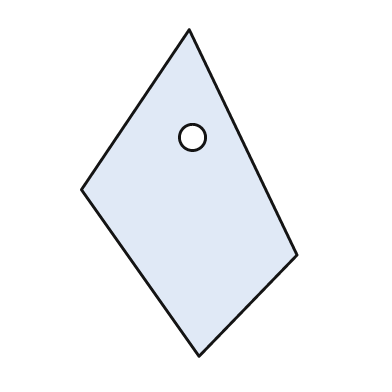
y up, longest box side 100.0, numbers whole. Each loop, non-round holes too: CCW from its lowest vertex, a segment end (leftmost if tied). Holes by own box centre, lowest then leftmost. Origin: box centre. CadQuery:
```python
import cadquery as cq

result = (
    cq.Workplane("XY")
    .moveTo(3.0, -50.0)
    .lineTo(33.0, -19.0)
    .lineTo(0.0, 50.0)
    .lineTo(-33.0, 1.0)
    .close()
    .moveTo(1.0, 17.0)
    .circle(4.0)
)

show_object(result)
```